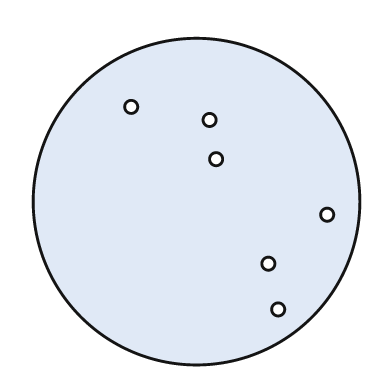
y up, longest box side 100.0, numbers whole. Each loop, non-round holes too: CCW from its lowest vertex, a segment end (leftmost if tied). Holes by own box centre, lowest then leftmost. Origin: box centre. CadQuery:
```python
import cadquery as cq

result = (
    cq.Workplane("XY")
    .moveTo(0.0, 0.0)
    .circle(50.0)
    .moveTo(25.0, -33.0)
    .circle(2.0)
    .moveTo(22.0, -19.0)
    .circle(2.0)
    .moveTo(40.0, -4.0)
    .circle(2.0)
    .moveTo(6.0, 13.0)
    .circle(2.0)
    .moveTo(4.0, 25.0)
    .circle(2.0)
    .moveTo(-20.0, 29.0)
    .circle(2.0)
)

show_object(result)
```